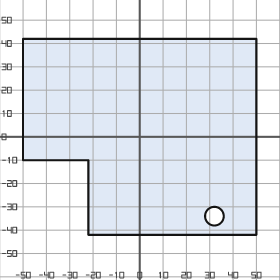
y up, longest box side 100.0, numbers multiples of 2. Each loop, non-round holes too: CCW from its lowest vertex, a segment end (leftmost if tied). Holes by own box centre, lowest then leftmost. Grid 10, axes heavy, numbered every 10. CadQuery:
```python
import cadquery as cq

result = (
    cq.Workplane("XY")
    .moveTo(-22.0, -42.0)
    .lineTo(50.0, -42.0)
    .lineTo(50.0, 42.0)
    .lineTo(-50.0, 42.0)
    .lineTo(-50.0, -10.0)
    .lineTo(-22.0, -10.0)
    .close()
    .moveTo(32.0, -34.0)
    .circle(4.0)
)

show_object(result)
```